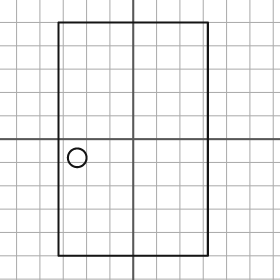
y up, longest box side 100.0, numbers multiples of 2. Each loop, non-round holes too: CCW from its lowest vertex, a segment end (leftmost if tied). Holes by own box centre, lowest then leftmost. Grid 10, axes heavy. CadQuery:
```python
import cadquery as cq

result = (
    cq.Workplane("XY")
    .moveTo(-32.0, -50.0)
    .lineTo(32.0, -50.0)
    .lineTo(32.0, 50.0)
    .lineTo(-32.0, 50.0)
    .close()
    .moveTo(-24.0, -8.0)
    .circle(4.0)
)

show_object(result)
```